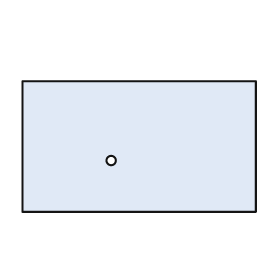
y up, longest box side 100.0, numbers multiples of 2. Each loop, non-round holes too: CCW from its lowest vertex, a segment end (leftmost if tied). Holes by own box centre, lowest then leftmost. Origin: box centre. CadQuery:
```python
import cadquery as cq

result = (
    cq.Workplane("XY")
    .moveTo(-50.0, -28.0)
    .lineTo(50.0, -28.0)
    .lineTo(50.0, 28.0)
    .lineTo(-50.0, 28.0)
    .close()
    .moveTo(-12.0, -6.0)
    .circle(2.0)
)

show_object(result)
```